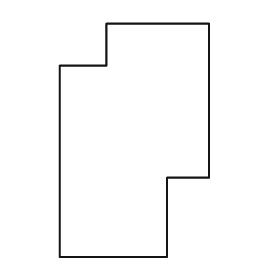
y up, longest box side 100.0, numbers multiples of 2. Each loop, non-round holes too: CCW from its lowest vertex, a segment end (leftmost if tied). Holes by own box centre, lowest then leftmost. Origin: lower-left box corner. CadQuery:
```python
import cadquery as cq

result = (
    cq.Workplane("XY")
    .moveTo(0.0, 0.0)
    .lineTo(46.0, 0.0)
    .lineTo(46.0, 34.0)
    .lineTo(64.0, 34.0)
    .lineTo(64.0, 100.0)
    .lineTo(20.0, 100.0)
    .lineTo(20.0, 82.0)
    .lineTo(0.0, 82.0)
    .close()
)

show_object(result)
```